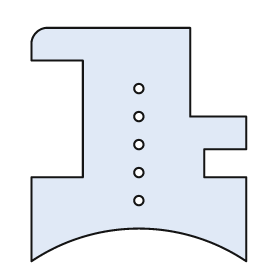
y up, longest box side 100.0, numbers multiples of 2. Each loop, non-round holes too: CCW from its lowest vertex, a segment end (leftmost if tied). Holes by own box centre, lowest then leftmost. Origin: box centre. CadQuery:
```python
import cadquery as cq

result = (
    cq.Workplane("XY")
    .moveTo(-46.0, -50.0)
    .threePointArc((0.0, -36.0), (46.0, -50.0))
    .lineTo(46.0, -14.0)
    .lineTo(28.0, -14.0)
    .lineTo(28.0, -2.0)
    .lineTo(46.0, -2.0)
    .lineTo(46.0, 12.0)
    .lineTo(22.0, 12.0)
    .lineTo(22.0, 50.0)
    .lineTo(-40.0, 50.0)
    .threePointArc((-44.0, 48.0), (-46.0, 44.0))
    .lineTo(-46.0, 36.0)
    .lineTo(-24.0, 36.0)
    .lineTo(-24.0, -14.0)
    .lineTo(-46.0, -14.0)
    .close()
    .moveTo(0.0, -24.0)
    .circle(2.0)
    .moveTo(0.0, -12.0)
    .circle(2.0)
    .moveTo(0.0, 0.0)
    .circle(2.0)
    .moveTo(0.0, 12.0)
    .circle(2.0)
    .moveTo(0.0, 24.0)
    .circle(2.0)
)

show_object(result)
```